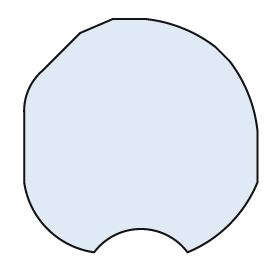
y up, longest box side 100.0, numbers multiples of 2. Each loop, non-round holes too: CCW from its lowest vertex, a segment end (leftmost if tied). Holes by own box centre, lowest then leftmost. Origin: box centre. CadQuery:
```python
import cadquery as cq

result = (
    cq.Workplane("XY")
    .moveTo(-20.0, -50.0)
    .threePointArc((0.0, -40.0), (20.0, -50.0))
    .threePointArc((38.0, -38.0), (50.0, -20.0))
    .lineTo(50.0, 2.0)
    .threePointArc((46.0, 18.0), (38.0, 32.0))
    .lineTo(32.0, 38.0)
    .threePointArc((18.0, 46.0), (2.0, 50.0))
    .lineTo(-12.0, 50.0)
    .lineTo(-26.0, 44.0)
    .lineTo(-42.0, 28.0)
    .threePointArc((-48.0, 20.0), (-50.0, 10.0))
    .lineTo(-50.0, -20.0)
    .threePointArc((-40.0, -40.0), (-20.0, -50.0))
    .close()
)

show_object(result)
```